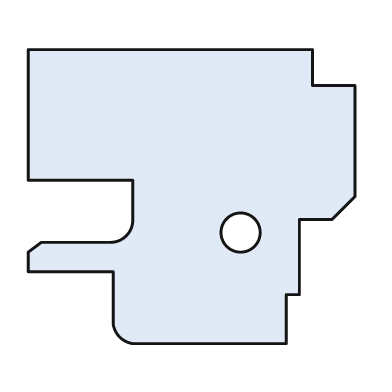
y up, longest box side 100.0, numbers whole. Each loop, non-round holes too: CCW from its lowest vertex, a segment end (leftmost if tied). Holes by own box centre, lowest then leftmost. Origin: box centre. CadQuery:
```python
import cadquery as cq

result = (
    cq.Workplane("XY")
    .moveTo(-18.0, -45.0)
    .lineTo(29.0, -45.0)
    .lineTo(29.0, -30.0)
    .lineTo(33.0, -30.0)
    .lineTo(33.0, -7.0)
    .lineTo(43.0, -7.0)
    .lineTo(50.0, 0.0)
    .lineTo(50.0, 34.0)
    .lineTo(37.0, 34.0)
    .lineTo(37.0, 45.0)
    .lineTo(-50.0, 45.0)
    .lineTo(-50.0, 5.0)
    .lineTo(-18.0, 5.0)
    .lineTo(-18.0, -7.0)
    .threePointArc((-20.0, -12.0), (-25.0, -14.0))
    .lineTo(-46.0, -14.0)
    .lineTo(-50.0, -17.0)
    .lineTo(-50.0, -23.0)
    .lineTo(-24.0, -23.0)
    .lineTo(-24.0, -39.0)
    .threePointArc((-22.0, -43.0), (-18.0, -45.0))
    .close()
    .moveTo(15.0, -11.0)
    .circle(6.0)
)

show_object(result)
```